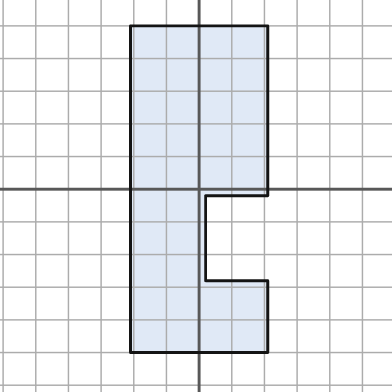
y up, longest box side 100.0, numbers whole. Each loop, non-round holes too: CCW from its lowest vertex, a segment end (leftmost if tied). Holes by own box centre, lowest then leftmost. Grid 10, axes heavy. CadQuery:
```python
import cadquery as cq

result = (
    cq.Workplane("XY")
    .moveTo(-21.0, -50.0)
    .lineTo(21.0, -50.0)
    .lineTo(21.0, -28.0)
    .lineTo(2.0, -28.0)
    .lineTo(2.0, -2.0)
    .lineTo(21.0, -2.0)
    .lineTo(21.0, 50.0)
    .lineTo(-21.0, 50.0)
    .close()
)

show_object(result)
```